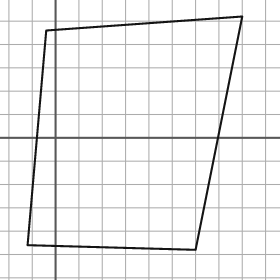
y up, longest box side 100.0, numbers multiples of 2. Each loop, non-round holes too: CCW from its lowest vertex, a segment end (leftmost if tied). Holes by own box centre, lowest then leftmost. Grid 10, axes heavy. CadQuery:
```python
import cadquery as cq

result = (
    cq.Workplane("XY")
    .moveTo(60.0, -48.0)
    .lineTo(80.0, 52.0)
    .lineTo(-4.0, 46.0)
    .lineTo(-12.0, -46.0)
    .close()
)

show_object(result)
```